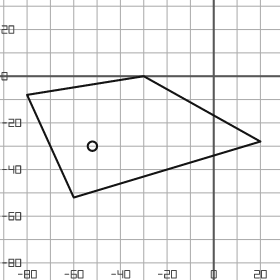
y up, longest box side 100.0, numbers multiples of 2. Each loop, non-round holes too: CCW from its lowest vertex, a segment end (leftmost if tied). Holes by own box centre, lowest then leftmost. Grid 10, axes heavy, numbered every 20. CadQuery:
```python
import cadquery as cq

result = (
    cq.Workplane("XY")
    .moveTo(-60.0, -52.0)
    .lineTo(20.0, -28.0)
    .lineTo(-30.0, 0.0)
    .lineTo(-80.0, -8.0)
    .close()
    .moveTo(-52.0, -30.0)
    .circle(2.0)
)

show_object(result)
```